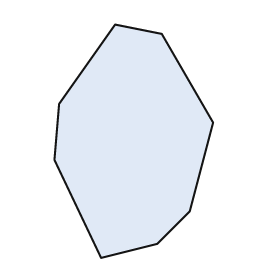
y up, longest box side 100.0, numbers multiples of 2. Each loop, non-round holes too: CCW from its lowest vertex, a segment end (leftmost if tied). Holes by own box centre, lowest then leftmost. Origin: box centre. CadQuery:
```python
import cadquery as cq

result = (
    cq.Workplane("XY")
    .moveTo(-14.0, -50.0)
    .lineTo(10.0, -44.0)
    .lineTo(24.0, -30.0)
    .lineTo(34.0, 8.0)
    .lineTo(12.0, 46.0)
    .lineTo(-8.0, 50.0)
    .lineTo(-32.0, 16.0)
    .lineTo(-34.0, -8.0)
    .close()
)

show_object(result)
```